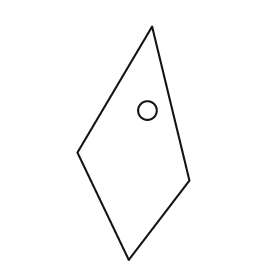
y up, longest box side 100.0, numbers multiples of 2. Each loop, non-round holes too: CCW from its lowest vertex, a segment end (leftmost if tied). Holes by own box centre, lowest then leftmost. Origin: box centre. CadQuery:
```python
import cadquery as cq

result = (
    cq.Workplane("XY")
    .moveTo(-2.0, -50.0)
    .lineTo(24.0, -16.0)
    .lineTo(8.0, 50.0)
    .lineTo(-24.0, -4.0)
    .close()
    .moveTo(6.0, 14.0)
    .circle(4.0)
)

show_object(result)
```